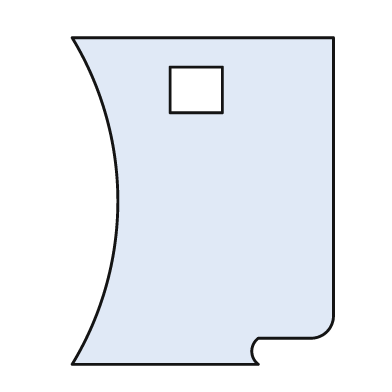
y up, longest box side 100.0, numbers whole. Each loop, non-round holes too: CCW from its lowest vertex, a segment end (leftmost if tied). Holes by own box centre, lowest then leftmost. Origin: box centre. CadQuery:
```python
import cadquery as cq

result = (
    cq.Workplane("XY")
    .moveTo(-40.0, -50.0)
    .lineTo(17.0, -50.0)
    .threePointArc((15.0, -46.0), (17.0, -42.0))
    .lineTo(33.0, -42.0)
    .threePointArc((38.0, -40.0), (40.0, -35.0))
    .lineTo(40.0, 50.0)
    .lineTo(-40.0, 50.0)
    .threePointArc((-26.0, 0.0), (-40.0, -50.0))
    .close()
    .moveTo(-10.0, 27.0)
    .lineTo(6.0, 27.0)
    .lineTo(6.0, 41.0)
    .lineTo(-10.0, 41.0)
    .close()
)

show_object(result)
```